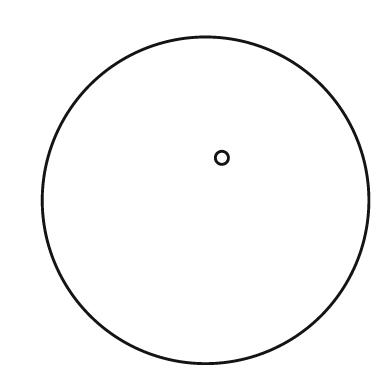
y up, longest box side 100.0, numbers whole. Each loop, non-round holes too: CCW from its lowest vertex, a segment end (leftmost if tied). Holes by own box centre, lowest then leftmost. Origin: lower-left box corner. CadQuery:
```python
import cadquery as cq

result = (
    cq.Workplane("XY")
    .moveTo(50.0, 50.0)
    .circle(50.0)
    .moveTo(55.0, 63.0)
    .circle(2.0)
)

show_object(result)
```